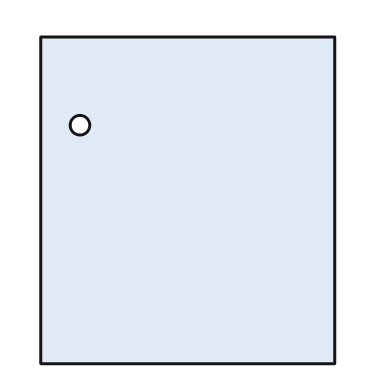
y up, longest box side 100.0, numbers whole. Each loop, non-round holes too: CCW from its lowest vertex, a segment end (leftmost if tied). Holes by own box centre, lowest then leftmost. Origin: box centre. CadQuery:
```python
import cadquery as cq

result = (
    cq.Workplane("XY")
    .moveTo(-45.0, -50.0)
    .lineTo(45.0, -50.0)
    .lineTo(45.0, 50.0)
    .lineTo(-45.0, 50.0)
    .close()
    .moveTo(-33.0, 23.0)
    .circle(3.0)
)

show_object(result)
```